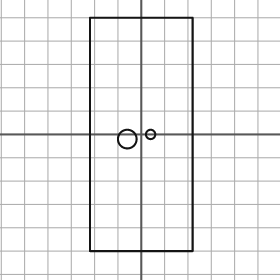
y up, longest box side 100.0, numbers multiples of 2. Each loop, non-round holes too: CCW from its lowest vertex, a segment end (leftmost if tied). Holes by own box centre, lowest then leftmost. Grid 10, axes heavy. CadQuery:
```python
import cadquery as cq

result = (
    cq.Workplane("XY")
    .moveTo(-22.0, -50.0)
    .lineTo(22.0, -50.0)
    .lineTo(22.0, 50.0)
    .lineTo(-22.0, 50.0)
    .close()
    .moveTo(-6.0, -2.0)
    .circle(4.0)
    .moveTo(4.0, 0.0)
    .circle(2.0)
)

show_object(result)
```